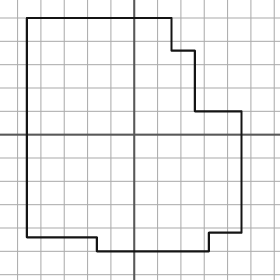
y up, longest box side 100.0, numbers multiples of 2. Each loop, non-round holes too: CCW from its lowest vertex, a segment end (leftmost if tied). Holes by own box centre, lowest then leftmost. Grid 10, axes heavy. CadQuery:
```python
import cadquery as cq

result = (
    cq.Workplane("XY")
    .moveTo(-16.0, -50.0)
    .lineTo(32.0, -50.0)
    .lineTo(32.0, -42.0)
    .lineTo(46.0, -42.0)
    .lineTo(46.0, 10.0)
    .lineTo(26.0, 10.0)
    .lineTo(26.0, 36.0)
    .lineTo(16.0, 36.0)
    .lineTo(16.0, 50.0)
    .lineTo(-46.0, 50.0)
    .lineTo(-46.0, -44.0)
    .lineTo(-16.0, -44.0)
    .close()
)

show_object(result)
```